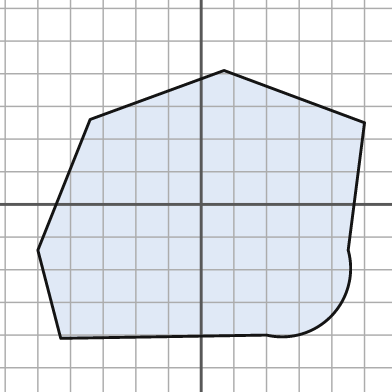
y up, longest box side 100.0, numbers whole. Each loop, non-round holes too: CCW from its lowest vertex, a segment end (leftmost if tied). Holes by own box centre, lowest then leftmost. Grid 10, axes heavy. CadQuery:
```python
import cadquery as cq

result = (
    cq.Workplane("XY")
    .moveTo(-43.0, -41.0)
    .lineTo(20.0, -40.0)
    .threePointArc((40.0, -34.0), (45.0, -14.0))
    .lineTo(50.0, 25.0)
    .lineTo(7.0, 41.0)
    .lineTo(-34.0, 26.0)
    .lineTo(-50.0, -14.0)
    .close()
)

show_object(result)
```